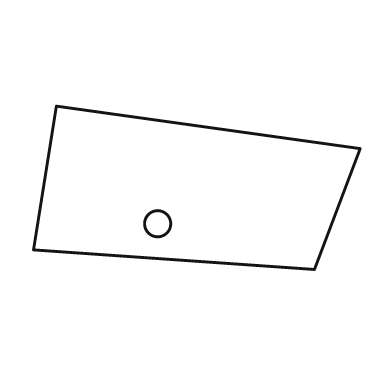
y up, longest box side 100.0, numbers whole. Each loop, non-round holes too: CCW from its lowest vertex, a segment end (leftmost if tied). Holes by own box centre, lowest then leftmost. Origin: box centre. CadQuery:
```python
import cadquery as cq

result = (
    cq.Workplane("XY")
    .moveTo(36.0, -25.0)
    .lineTo(50.0, 12.0)
    .lineTo(-43.0, 25.0)
    .lineTo(-50.0, -19.0)
    .close()
    .moveTo(-12.0, -11.0)
    .circle(4.0)
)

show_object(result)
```